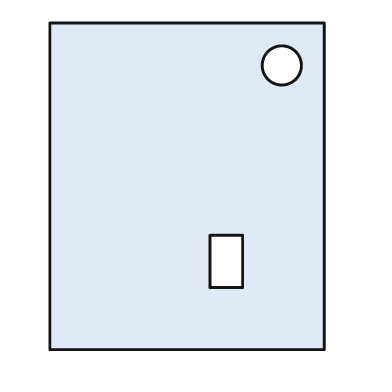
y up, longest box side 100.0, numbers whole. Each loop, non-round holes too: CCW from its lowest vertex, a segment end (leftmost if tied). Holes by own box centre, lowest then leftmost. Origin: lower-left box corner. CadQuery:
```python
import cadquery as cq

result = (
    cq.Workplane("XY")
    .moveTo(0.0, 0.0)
    .lineTo(84.0, 0.0)
    .lineTo(84.0, 100.0)
    .lineTo(0.0, 100.0)
    .close()
    .moveTo(49.0, 19.0)
    .lineTo(59.0, 19.0)
    .lineTo(59.0, 35.0)
    .lineTo(49.0, 35.0)
    .close()
    .moveTo(71.0, 87.0)
    .circle(6.0)
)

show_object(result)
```